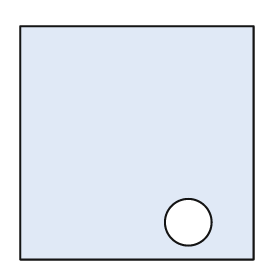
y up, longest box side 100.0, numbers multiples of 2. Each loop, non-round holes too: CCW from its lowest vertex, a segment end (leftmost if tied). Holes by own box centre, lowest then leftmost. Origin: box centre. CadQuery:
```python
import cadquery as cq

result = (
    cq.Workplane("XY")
    .moveTo(-50.0, -50.0)
    .lineTo(50.0, -50.0)
    .lineTo(50.0, 50.0)
    .lineTo(-50.0, 50.0)
    .close()
    .moveTo(22.0, -34.0)
    .circle(10.0)
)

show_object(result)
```